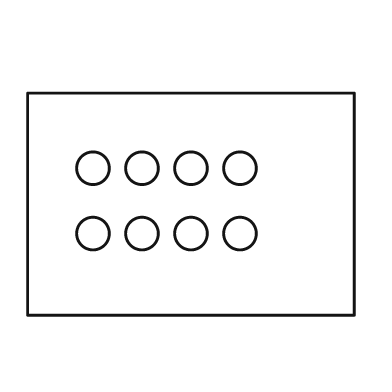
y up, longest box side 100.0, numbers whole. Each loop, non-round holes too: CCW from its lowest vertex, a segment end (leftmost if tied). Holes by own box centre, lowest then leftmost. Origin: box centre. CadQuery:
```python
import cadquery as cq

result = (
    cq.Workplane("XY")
    .moveTo(-50.0, -34.0)
    .lineTo(50.0, -34.0)
    .lineTo(50.0, 34.0)
    .lineTo(-50.0, 34.0)
    .close()
    .moveTo(-30.0, -9.0)
    .circle(5.0)
    .moveTo(-15.0, -9.0)
    .circle(5.0)
    .moveTo(0.0, -9.0)
    .circle(5.0)
    .moveTo(15.0, -9.0)
    .circle(5.0)
    .moveTo(-30.0, 11.0)
    .circle(5.0)
    .moveTo(-15.0, 11.0)
    .circle(5.0)
    .moveTo(0.0, 11.0)
    .circle(5.0)
    .moveTo(15.0, 11.0)
    .circle(5.0)
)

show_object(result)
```